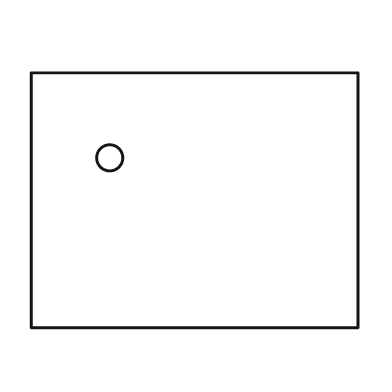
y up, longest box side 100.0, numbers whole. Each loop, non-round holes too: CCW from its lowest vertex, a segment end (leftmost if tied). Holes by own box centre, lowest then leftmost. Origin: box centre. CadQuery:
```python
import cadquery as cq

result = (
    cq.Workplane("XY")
    .moveTo(-50.0, -39.0)
    .lineTo(50.0, -39.0)
    .lineTo(50.0, 39.0)
    .lineTo(-50.0, 39.0)
    .close()
    .moveTo(-26.0, 13.0)
    .circle(4.0)
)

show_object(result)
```